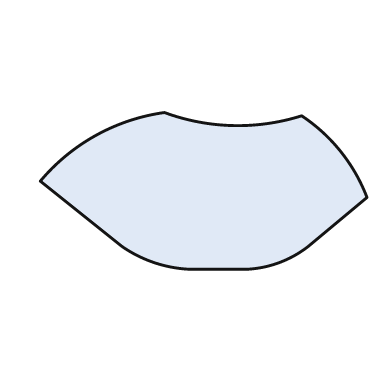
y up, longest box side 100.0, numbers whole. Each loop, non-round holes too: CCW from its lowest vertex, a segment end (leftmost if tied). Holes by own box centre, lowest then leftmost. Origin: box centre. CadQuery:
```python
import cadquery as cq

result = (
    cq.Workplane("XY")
    .moveTo(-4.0, -24.0)
    .lineTo(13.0, -24.0)
    .threePointArc((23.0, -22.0), (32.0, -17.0))
    .lineTo(50.0, -2.0)
    .threePointArc((42.0, 12.0), (30.0, 23.0))
    .threePointArc((9.0, 20.0), (-12.0, 24.0))
    .threePointArc((-33.0, 17.0), (-50.0, 3.0))
    .lineTo(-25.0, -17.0)
    .threePointArc((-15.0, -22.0), (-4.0, -24.0))
    .close()
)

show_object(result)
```